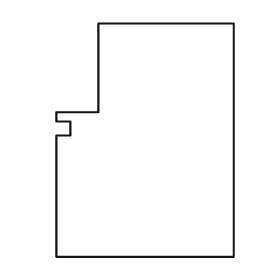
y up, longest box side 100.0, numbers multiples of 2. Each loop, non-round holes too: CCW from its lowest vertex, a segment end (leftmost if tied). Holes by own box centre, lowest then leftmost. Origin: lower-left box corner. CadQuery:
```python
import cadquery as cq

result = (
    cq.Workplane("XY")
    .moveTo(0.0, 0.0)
    .lineTo(76.0, 0.0)
    .lineTo(76.0, 100.0)
    .lineTo(18.0, 100.0)
    .lineTo(18.0, 62.0)
    .lineTo(0.0, 62.0)
    .lineTo(0.0, 58.0)
    .lineTo(6.0, 58.0)
    .lineTo(6.0, 52.0)
    .lineTo(0.0, 52.0)
    .close()
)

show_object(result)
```